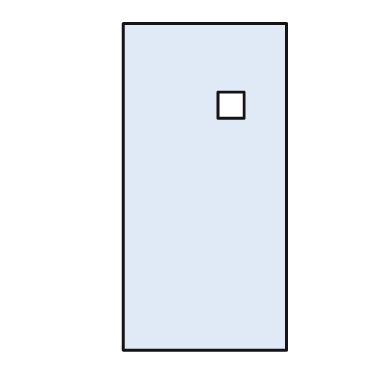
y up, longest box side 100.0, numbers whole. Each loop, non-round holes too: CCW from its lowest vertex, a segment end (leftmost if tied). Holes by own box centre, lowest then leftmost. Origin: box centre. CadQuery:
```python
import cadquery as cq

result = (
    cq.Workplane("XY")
    .moveTo(-25.0, -50.0)
    .lineTo(25.0, -50.0)
    .lineTo(25.0, 50.0)
    .lineTo(-25.0, 50.0)
    .close()
    .moveTo(4.0, 21.0)
    .lineTo(12.0, 21.0)
    .lineTo(12.0, 29.0)
    .lineTo(4.0, 29.0)
    .close()
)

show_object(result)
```